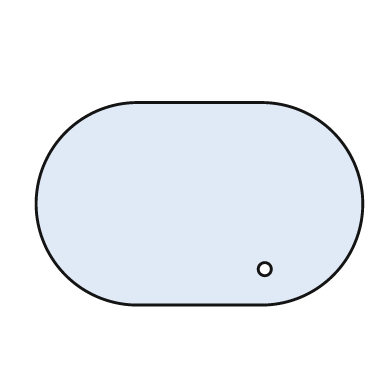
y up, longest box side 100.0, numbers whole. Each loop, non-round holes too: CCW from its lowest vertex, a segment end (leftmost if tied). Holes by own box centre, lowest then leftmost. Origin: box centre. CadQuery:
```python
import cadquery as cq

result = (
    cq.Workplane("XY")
    .moveTo(-19.0, -31.0)
    .lineTo(19.0, -31.0)
    .threePointArc((50.0, 0.0), (19.0, 31.0))
    .lineTo(-19.0, 31.0)
    .threePointArc((-50.0, 0.0), (-19.0, -31.0))
    .close()
    .moveTo(20.0, -20.0)
    .circle(2.0)
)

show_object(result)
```